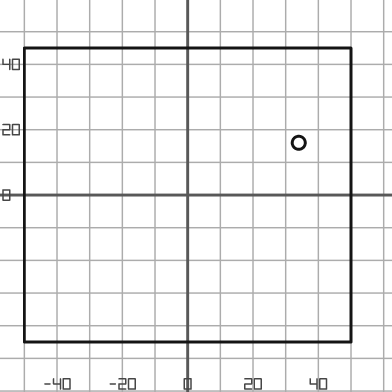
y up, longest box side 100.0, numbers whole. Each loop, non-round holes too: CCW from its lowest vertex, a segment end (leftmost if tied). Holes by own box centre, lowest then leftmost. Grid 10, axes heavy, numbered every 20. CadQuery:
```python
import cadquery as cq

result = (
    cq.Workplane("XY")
    .moveTo(-50.0, -45.0)
    .lineTo(50.0, -45.0)
    .lineTo(50.0, 45.0)
    .lineTo(-50.0, 45.0)
    .close()
    .moveTo(34.0, 16.0)
    .circle(2.0)
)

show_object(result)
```